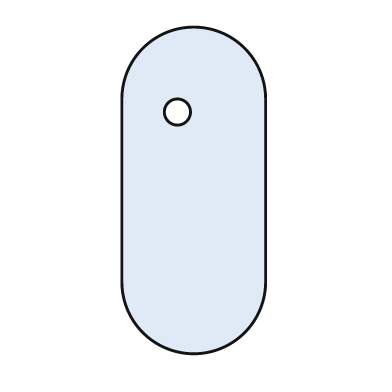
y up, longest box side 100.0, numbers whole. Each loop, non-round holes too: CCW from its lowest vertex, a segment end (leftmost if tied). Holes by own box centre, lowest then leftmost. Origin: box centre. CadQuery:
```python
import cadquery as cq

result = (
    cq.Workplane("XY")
    .moveTo(-22.0, -28.0)
    .threePointArc((0.0, -50.0), (22.0, -28.0))
    .lineTo(22.0, 28.0)
    .threePointArc((0.0, 50.0), (-22.0, 28.0))
    .close()
    .moveTo(-5.0, 24.0)
    .circle(4.0)
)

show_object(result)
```